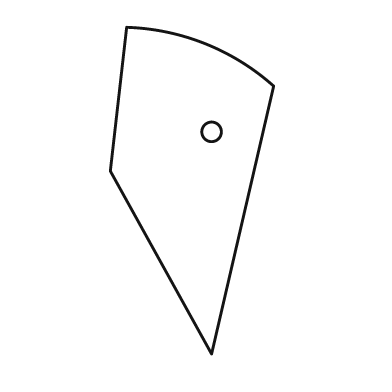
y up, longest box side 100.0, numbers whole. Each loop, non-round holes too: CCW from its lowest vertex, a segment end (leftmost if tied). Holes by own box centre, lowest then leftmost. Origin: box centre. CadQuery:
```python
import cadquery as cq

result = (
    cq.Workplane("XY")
    .moveTo(6.0, -50.0)
    .lineTo(25.0, 32.0)
    .threePointArc((4.0, 45.0), (-20.0, 50.0))
    .lineTo(-25.0, 6.0)
    .close()
    .moveTo(6.0, 18.0)
    .circle(3.0)
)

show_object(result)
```